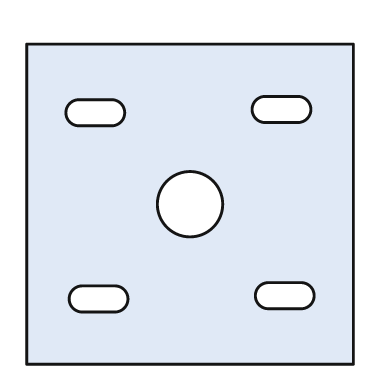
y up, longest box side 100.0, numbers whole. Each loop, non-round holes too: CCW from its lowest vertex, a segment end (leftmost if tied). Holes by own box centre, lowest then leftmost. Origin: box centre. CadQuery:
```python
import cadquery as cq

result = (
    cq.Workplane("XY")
    .moveTo(-50.0, -49.0)
    .lineTo(50.0, -49.0)
    .lineTo(50.0, 49.0)
    .lineTo(-50.0, 49.0)
    .close()
    .moveTo(-33.0, -33.0)
    .lineTo(-23.0, -33.0)
    .threePointArc((-19.0, -29.0), (-23.0, -25.0))
    .lineTo(-33.0, -25.0)
    .threePointArc((-37.0, -29.0), (-33.0, -33.0))
    .close()
    .moveTo(24.0, -32.0)
    .lineTo(34.0, -32.0)
    .threePointArc((38.0, -28.0), (34.0, -24.0))
    .lineTo(24.0, -24.0)
    .threePointArc((20.0, -28.0), (24.0, -32.0))
    .close()
    .moveTo(0.0, 0.0)
    .circle(10.0)
    .moveTo(-34.0, 24.0)
    .lineTo(-24.0, 24.0)
    .threePointArc((-20.0, 28.0), (-24.0, 32.0))
    .lineTo(-34.0, 32.0)
    .threePointArc((-38.0, 28.0), (-34.0, 24.0))
    .close()
    .moveTo(23.0, 25.0)
    .lineTo(33.0, 25.0)
    .threePointArc((37.0, 29.0), (33.0, 33.0))
    .lineTo(23.0, 33.0)
    .threePointArc((19.0, 29.0), (23.0, 25.0))
    .close()
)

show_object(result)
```